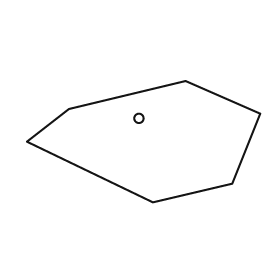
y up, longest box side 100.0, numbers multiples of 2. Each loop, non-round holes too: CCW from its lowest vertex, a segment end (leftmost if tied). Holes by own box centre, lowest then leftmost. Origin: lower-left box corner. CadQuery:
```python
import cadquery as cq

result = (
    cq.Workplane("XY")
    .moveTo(54.0, 0.0)
    .lineTo(88.0, 8.0)
    .lineTo(100.0, 38.0)
    .lineTo(68.0, 52.0)
    .lineTo(18.0, 40.0)
    .lineTo(0.0, 26.0)
    .close()
    .moveTo(48.0, 36.0)
    .circle(2.0)
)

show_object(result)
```